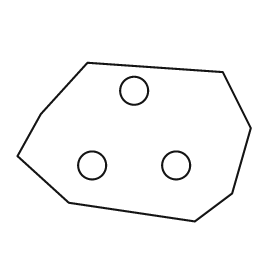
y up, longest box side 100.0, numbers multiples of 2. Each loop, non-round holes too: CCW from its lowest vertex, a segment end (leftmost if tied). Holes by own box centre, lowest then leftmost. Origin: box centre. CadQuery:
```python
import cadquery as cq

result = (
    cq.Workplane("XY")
    .moveTo(26.0, -34.0)
    .lineTo(42.0, -22.0)
    .lineTo(50.0, 6.0)
    .lineTo(38.0, 30.0)
    .lineTo(-20.0, 34.0)
    .lineTo(-40.0, 12.0)
    .lineTo(-50.0, -6.0)
    .lineTo(-28.0, -26.0)
    .close()
    .moveTo(-18.0, -10.0)
    .circle(6.0)
    .moveTo(18.0, -10.0)
    .circle(6.0)
    .moveTo(0.0, 22.0)
    .circle(6.0)
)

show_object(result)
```